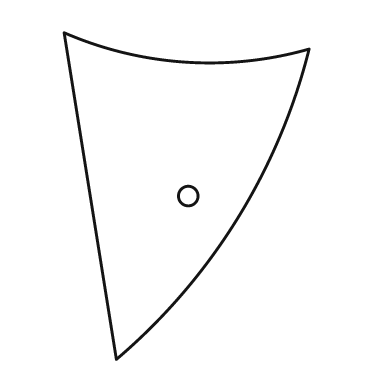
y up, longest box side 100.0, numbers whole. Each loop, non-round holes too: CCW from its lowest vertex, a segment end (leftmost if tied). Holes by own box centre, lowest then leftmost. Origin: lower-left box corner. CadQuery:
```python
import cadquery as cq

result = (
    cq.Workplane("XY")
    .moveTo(16.0, 0.0)
    .threePointArc((53.0, 43.0), (75.0, 95.0))
    .threePointArc((37.0, 91.0), (0.0, 100.0))
    .close()
    .moveTo(38.0, 50.0)
    .circle(3.0)
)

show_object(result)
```